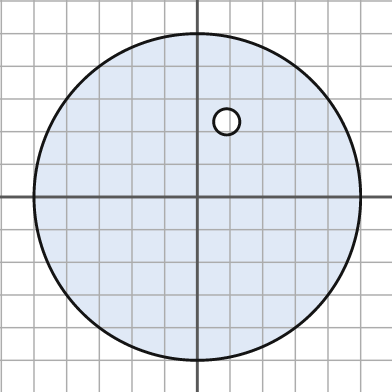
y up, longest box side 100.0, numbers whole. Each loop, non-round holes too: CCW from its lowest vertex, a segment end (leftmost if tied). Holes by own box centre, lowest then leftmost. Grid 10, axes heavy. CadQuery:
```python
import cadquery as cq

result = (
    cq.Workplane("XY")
    .moveTo(0.0, 0.0)
    .circle(50.0)
    .moveTo(9.0, 23.0)
    .circle(4.0)
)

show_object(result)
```